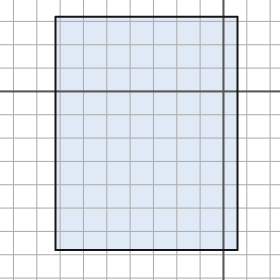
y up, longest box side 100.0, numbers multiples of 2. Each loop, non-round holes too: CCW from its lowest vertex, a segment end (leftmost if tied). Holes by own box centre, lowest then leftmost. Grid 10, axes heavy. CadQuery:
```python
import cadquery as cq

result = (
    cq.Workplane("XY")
    .moveTo(-72.0, -68.0)
    .lineTo(6.0, -68.0)
    .lineTo(6.0, 32.0)
    .lineTo(-72.0, 32.0)
    .close()
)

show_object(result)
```